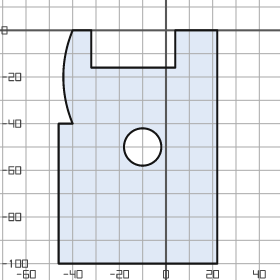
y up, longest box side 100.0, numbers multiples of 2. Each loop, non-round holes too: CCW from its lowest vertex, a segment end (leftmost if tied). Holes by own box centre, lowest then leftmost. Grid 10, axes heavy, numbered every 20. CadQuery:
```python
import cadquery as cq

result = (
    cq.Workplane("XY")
    .moveTo(-46.0, -100.0)
    .lineTo(22.0, -100.0)
    .lineTo(22.0, 0.0)
    .lineTo(4.0, 0.0)
    .lineTo(4.0, -16.0)
    .lineTo(-32.0, -16.0)
    .lineTo(-32.0, 0.0)
    .lineTo(-40.0, 0.0)
    .threePointArc((-44.0, -20.0), (-40.0, -40.0))
    .lineTo(-46.0, -40.0)
    .close()
    .moveTo(-10.0, -50.0)
    .circle(8.0)
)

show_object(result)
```